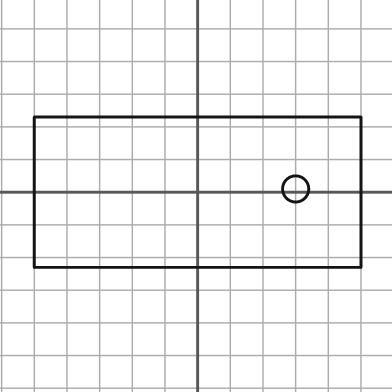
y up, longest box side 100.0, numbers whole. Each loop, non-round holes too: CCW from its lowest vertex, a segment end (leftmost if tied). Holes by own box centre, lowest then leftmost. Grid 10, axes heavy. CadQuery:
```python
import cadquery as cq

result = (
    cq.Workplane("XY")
    .moveTo(-50.0, -23.0)
    .lineTo(50.0, -23.0)
    .lineTo(50.0, 23.0)
    .lineTo(-50.0, 23.0)
    .close()
    .moveTo(30.0, 1.0)
    .circle(4.0)
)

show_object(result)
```